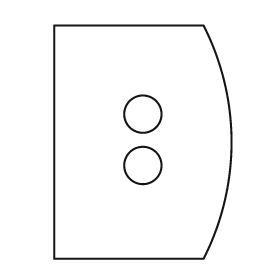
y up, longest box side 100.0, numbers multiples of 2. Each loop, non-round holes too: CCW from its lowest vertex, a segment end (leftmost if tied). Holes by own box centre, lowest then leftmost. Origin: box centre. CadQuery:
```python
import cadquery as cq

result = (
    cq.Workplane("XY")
    .moveTo(-38.0, -50.0)
    .lineTo(26.0, -50.0)
    .threePointArc((38.0, 0.0), (26.0, 50.0))
    .lineTo(-38.0, 50.0)
    .close()
    .moveTo(0.0, -10.0)
    .circle(8.0)
    .moveTo(0.0, 12.0)
    .circle(8.0)
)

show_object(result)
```